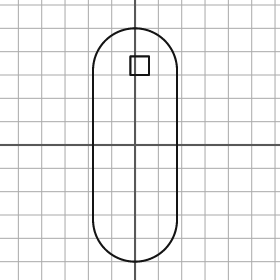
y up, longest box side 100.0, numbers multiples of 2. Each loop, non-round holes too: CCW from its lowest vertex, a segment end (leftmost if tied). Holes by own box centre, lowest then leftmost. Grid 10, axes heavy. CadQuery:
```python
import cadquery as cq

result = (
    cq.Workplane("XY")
    .moveTo(-18.0, -32.0)
    .threePointArc((0.0, -50.0), (18.0, -32.0))
    .lineTo(18.0, 32.0)
    .threePointArc((0.0, 50.0), (-18.0, 32.0))
    .close()
    .moveTo(-2.0, 30.0)
    .lineTo(6.0, 30.0)
    .lineTo(6.0, 38.0)
    .lineTo(-2.0, 38.0)
    .close()
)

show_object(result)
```